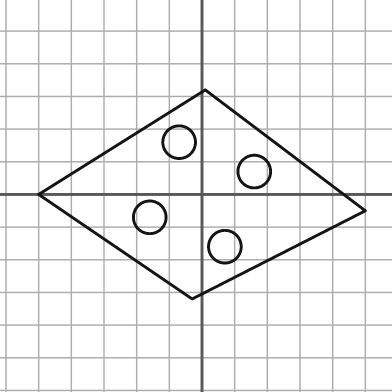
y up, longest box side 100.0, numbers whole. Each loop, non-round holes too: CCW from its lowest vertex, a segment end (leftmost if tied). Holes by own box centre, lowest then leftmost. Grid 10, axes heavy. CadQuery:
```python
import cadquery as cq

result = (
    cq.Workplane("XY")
    .moveTo(-3.0, -32.0)
    .lineTo(50.0, -5.0)
    .lineTo(1.0, 32.0)
    .lineTo(-50.0, 0.0)
    .close()
    .moveTo(7.0, -16.0)
    .circle(5.0)
    .moveTo(-16.0, -7.0)
    .circle(5.0)
    .moveTo(16.0, 7.0)
    .circle(5.0)
    .moveTo(-7.0, 16.0)
    .circle(5.0)
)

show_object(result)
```